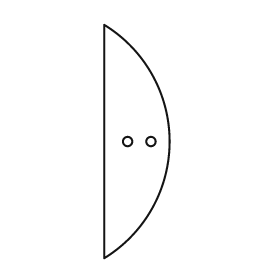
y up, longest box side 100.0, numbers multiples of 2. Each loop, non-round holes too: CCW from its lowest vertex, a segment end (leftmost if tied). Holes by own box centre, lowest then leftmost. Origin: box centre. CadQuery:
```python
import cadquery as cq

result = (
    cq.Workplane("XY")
    .moveTo(-14.0, -50.0)
    .threePointArc((14.0, 0.0), (-14.0, 50.0))
    .close()
    .moveTo(-4.0, 0.0)
    .circle(2.0)
    .moveTo(6.0, 0.0)
    .circle(2.0)
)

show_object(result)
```